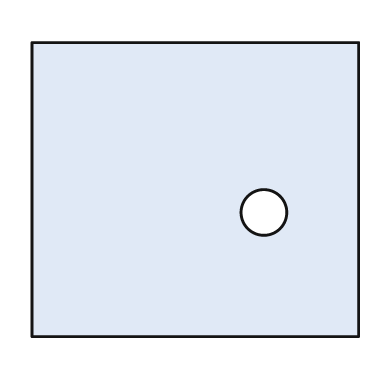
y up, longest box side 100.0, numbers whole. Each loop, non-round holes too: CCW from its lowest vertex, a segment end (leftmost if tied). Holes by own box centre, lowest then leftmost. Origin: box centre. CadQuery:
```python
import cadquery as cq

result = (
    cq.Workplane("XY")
    .moveTo(-50.0, -45.0)
    .lineTo(50.0, -45.0)
    .lineTo(50.0, 45.0)
    .lineTo(-50.0, 45.0)
    .close()
    .moveTo(21.0, -7.0)
    .circle(7.0)
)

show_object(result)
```